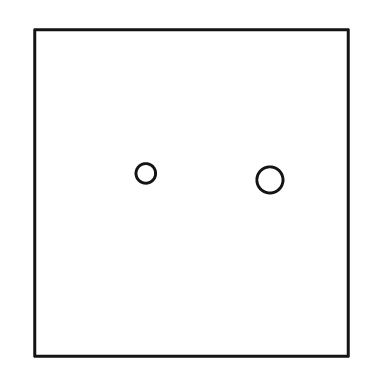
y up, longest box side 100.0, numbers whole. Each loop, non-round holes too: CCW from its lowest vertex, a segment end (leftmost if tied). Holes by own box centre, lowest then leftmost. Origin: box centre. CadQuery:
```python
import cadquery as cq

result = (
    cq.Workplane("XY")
    .moveTo(-48.0, -50.0)
    .lineTo(48.0, -50.0)
    .lineTo(48.0, 50.0)
    .lineTo(-48.0, 50.0)
    .close()
    .moveTo(24.0, 4.0)
    .circle(4.0)
    .moveTo(-14.0, 6.0)
    .circle(3.0)
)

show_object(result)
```